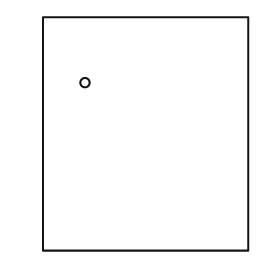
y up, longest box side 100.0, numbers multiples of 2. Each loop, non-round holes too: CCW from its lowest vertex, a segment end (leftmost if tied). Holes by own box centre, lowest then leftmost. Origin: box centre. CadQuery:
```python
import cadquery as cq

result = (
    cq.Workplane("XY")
    .moveTo(-44.0, -50.0)
    .lineTo(44.0, -50.0)
    .lineTo(44.0, 50.0)
    .lineTo(-44.0, 50.0)
    .close()
    .moveTo(-26.0, 22.0)
    .circle(2.0)
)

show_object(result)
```